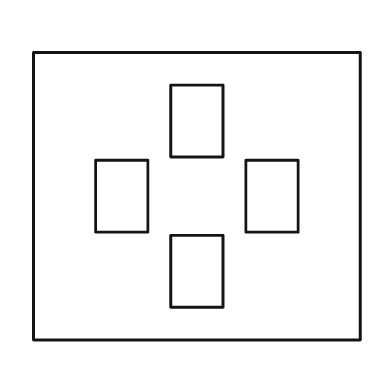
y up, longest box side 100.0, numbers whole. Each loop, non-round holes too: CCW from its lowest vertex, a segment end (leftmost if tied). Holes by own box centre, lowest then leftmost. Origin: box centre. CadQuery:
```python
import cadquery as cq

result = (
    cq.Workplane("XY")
    .moveTo(-50.0, -44.0)
    .lineTo(50.0, -44.0)
    .lineTo(50.0, 44.0)
    .lineTo(-50.0, 44.0)
    .close()
    .moveTo(-8.0, -34.0)
    .lineTo(8.0, -34.0)
    .lineTo(8.0, -12.0)
    .lineTo(-8.0, -12.0)
    .close()
    .moveTo(-31.0, -11.0)
    .lineTo(-15.0, -11.0)
    .lineTo(-15.0, 11.0)
    .lineTo(-31.0, 11.0)
    .close()
    .moveTo(15.0, -11.0)
    .lineTo(31.0, -11.0)
    .lineTo(31.0, 11.0)
    .lineTo(15.0, 11.0)
    .close()
    .moveTo(-8.0, 12.0)
    .lineTo(8.0, 12.0)
    .lineTo(8.0, 34.0)
    .lineTo(-8.0, 34.0)
    .close()
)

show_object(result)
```